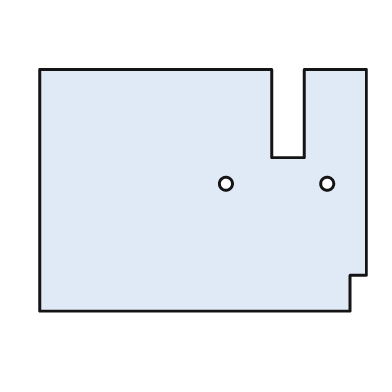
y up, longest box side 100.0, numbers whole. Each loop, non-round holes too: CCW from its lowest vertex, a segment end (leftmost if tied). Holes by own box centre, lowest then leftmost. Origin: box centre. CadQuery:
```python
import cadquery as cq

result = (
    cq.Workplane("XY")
    .moveTo(-50.0, -37.0)
    .lineTo(45.0, -37.0)
    .lineTo(45.0, -26.0)
    .lineTo(50.0, -26.0)
    .lineTo(50.0, 37.0)
    .lineTo(31.0, 37.0)
    .lineTo(31.0, 10.0)
    .lineTo(21.0, 10.0)
    .lineTo(21.0, 37.0)
    .lineTo(-50.0, 37.0)
    .close()
    .moveTo(7.0, 2.0)
    .circle(2.0)
    .moveTo(38.0, 2.0)
    .circle(2.0)
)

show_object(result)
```